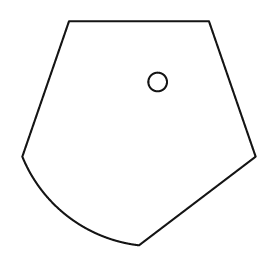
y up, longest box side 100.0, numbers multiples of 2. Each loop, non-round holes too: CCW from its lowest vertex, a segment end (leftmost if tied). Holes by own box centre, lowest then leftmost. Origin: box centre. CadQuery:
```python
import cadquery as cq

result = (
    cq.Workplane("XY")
    .moveTo(0.0, -48.0)
    .lineTo(50.0, -10.0)
    .lineTo(30.0, 48.0)
    .lineTo(-30.0, 48.0)
    .lineTo(-50.0, -10.0)
    .threePointArc((-30.0, -36.0), (0.0, -48.0))
    .close()
    .moveTo(8.0, 22.0)
    .circle(4.0)
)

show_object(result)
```